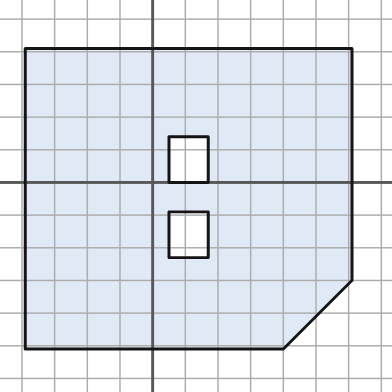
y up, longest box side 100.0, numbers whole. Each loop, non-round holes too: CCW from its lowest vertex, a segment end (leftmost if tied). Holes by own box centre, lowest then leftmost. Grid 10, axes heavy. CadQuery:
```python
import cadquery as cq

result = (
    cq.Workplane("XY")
    .moveTo(-39.0, -51.0)
    .lineTo(40.0, -51.0)
    .lineTo(61.0, -30.0)
    .lineTo(61.0, 41.0)
    .lineTo(-39.0, 41.0)
    .close()
    .moveTo(5.0, -23.0)
    .lineTo(17.0, -23.0)
    .lineTo(17.0, -9.0)
    .lineTo(5.0, -9.0)
    .close()
    .moveTo(5.0, 0.0)
    .lineTo(17.0, 0.0)
    .lineTo(17.0, 14.0)
    .lineTo(5.0, 14.0)
    .close()
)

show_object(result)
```